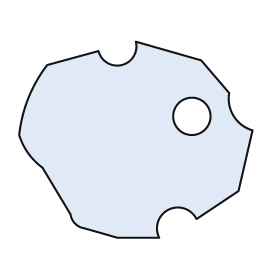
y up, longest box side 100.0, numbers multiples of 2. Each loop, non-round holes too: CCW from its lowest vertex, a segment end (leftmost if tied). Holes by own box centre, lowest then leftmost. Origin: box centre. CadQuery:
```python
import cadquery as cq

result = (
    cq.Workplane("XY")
    .moveTo(-8.0, -42.0)
    .lineTo(10.0, -42.0)
    .threePointArc((14.0, -30.0), (26.0, -34.0))
    .lineTo(44.0, -22.0)
    .lineTo(50.0, 4.0)
    .threePointArc((42.0, 10.0), (40.0, 20.0))
    .lineTo(28.0, 34.0)
    .lineTo(0.0, 42.0)
    .threePointArc((-6.0, 32.0), (-16.0, 38.0))
    .lineTo(-38.0, 32.0)
    .threePointArc((-46.0, 18.0), (-50.0, 2.0))
    .threePointArc((-46.0, -6.0), (-40.0, -12.0))
    .lineTo(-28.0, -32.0)
    .threePointArc((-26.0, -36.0), (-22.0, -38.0))
    .close()
    .moveTo(24.0, 10.0)
    .circle(8.0)
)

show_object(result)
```